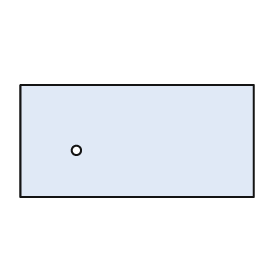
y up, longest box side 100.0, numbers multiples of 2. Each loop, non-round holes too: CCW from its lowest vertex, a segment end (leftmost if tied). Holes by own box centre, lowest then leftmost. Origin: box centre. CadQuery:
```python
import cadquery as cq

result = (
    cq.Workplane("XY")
    .moveTo(-50.0, -24.0)
    .lineTo(50.0, -24.0)
    .lineTo(50.0, 24.0)
    .lineTo(-50.0, 24.0)
    .close()
    .moveTo(-26.0, -4.0)
    .circle(2.0)
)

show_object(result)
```